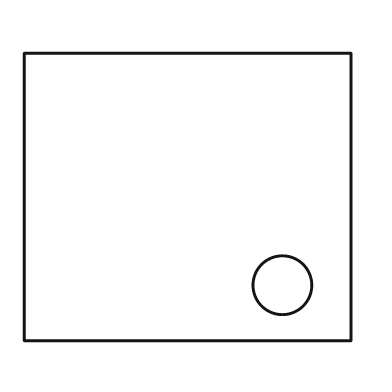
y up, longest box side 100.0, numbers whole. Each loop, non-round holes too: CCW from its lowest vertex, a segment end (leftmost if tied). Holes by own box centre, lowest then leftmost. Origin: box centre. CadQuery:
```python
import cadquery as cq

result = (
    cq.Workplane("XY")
    .moveTo(-50.0, -44.0)
    .lineTo(50.0, -44.0)
    .lineTo(50.0, 44.0)
    .lineTo(-50.0, 44.0)
    .close()
    .moveTo(29.0, -27.0)
    .circle(9.0)
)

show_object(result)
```